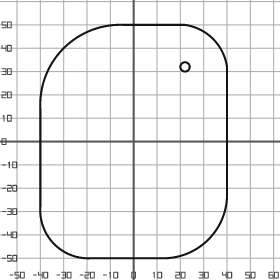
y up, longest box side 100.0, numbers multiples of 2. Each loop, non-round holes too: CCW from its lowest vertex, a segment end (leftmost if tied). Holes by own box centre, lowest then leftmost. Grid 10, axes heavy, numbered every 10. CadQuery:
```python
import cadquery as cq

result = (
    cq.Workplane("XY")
    .moveTo(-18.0, -50.0)
    .lineTo(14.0, -50.0)
    .threePointArc((32.0, -42.0), (40.0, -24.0))
    .lineTo(40.0, 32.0)
    .threePointArc((34.0, 44.0), (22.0, 50.0))
    .lineTo(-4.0, 50.0)
    .threePointArc((-30.0, 40.0), (-40.0, 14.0))
    .lineTo(-40.0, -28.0)
    .threePointArc((-34.0, -44.0), (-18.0, -50.0))
    .close()
    .moveTo(22.0, 32.0)
    .circle(2.0)
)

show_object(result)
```